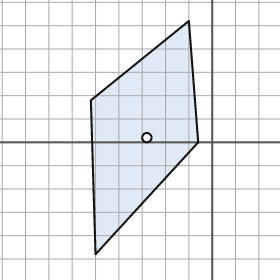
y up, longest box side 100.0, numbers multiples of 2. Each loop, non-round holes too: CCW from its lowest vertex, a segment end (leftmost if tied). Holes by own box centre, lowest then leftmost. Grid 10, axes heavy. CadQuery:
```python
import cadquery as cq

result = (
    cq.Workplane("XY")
    .moveTo(-50.0, -48.0)
    .lineTo(-6.0, 0.0)
    .lineTo(-10.0, 52.0)
    .lineTo(-52.0, 18.0)
    .close()
    .moveTo(-28.0, 2.0)
    .circle(2.0)
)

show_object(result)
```